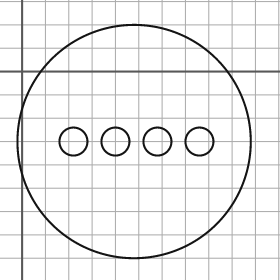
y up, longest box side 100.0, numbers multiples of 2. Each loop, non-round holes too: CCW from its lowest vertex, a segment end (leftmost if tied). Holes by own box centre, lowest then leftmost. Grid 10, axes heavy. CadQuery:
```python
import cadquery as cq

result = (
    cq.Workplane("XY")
    .moveTo(48.0, -30.0)
    .circle(50.0)
    .moveTo(22.0, -30.0)
    .circle(6.0)
    .moveTo(40.0, -30.0)
    .circle(6.0)
    .moveTo(58.0, -30.0)
    .circle(6.0)
    .moveTo(76.0, -30.0)
    .circle(6.0)
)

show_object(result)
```